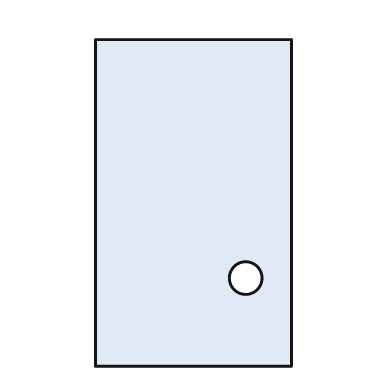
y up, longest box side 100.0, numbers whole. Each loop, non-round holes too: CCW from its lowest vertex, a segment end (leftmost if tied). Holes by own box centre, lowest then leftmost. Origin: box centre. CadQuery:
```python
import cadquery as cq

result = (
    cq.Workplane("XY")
    .moveTo(-30.0, -50.0)
    .lineTo(30.0, -50.0)
    .lineTo(30.0, 50.0)
    .lineTo(-30.0, 50.0)
    .close()
    .moveTo(16.0, -23.0)
    .circle(5.0)
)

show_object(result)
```